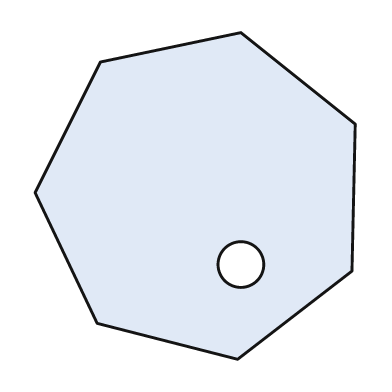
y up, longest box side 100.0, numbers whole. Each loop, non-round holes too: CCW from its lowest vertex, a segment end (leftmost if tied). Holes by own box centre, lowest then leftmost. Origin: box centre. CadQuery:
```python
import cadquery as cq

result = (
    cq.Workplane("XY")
    .moveTo(13.0, -50.0)
    .lineTo(48.0, -23.0)
    .lineTo(49.0, 22.0)
    .lineTo(14.0, 50.0)
    .lineTo(-29.0, 41.0)
    .lineTo(-49.0, 1.0)
    .lineTo(-30.0, -39.0)
    .close()
    .moveTo(14.0, -21.0)
    .circle(7.0)
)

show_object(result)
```